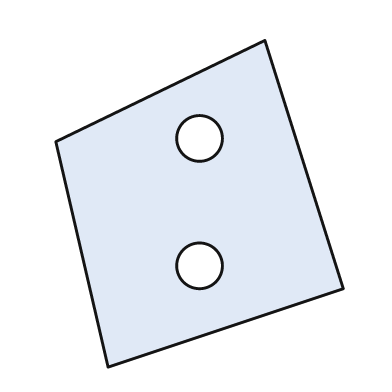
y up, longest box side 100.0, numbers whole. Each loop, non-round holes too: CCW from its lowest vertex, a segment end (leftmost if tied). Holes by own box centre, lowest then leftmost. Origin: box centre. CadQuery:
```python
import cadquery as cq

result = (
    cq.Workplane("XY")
    .moveTo(-28.0, -50.0)
    .lineTo(44.0, -26.0)
    .lineTo(20.0, 50.0)
    .lineTo(-44.0, 19.0)
    .close()
    .moveTo(0.0, -19.0)
    .circle(7.0)
    .moveTo(0.0, 20.0)
    .circle(7.0)
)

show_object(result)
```